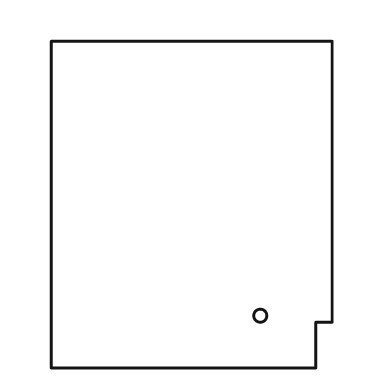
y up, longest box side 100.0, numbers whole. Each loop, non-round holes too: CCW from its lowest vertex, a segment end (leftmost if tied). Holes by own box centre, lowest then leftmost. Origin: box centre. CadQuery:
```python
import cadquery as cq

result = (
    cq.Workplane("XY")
    .moveTo(-43.0, -50.0)
    .lineTo(38.0, -50.0)
    .lineTo(38.0, -36.0)
    .lineTo(43.0, -36.0)
    .lineTo(43.0, 50.0)
    .lineTo(-43.0, 50.0)
    .close()
    .moveTo(21.0, -34.0)
    .circle(2.0)
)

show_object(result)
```